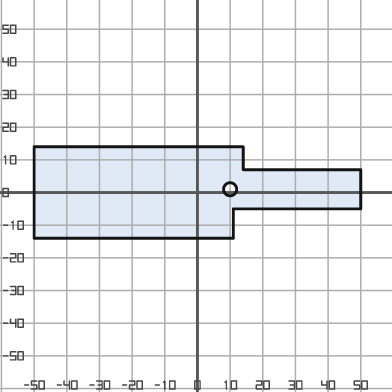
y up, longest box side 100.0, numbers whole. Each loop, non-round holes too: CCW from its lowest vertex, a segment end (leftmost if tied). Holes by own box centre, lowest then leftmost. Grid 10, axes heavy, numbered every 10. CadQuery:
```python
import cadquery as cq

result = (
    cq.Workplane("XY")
    .moveTo(-50.0, -14.0)
    .lineTo(11.0, -14.0)
    .lineTo(11.0, -5.0)
    .lineTo(50.0, -5.0)
    .lineTo(50.0, 7.0)
    .lineTo(14.0, 7.0)
    .lineTo(14.0, 14.0)
    .lineTo(-50.0, 14.0)
    .close()
    .moveTo(10.0, 1.0)
    .circle(2.0)
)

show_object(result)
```